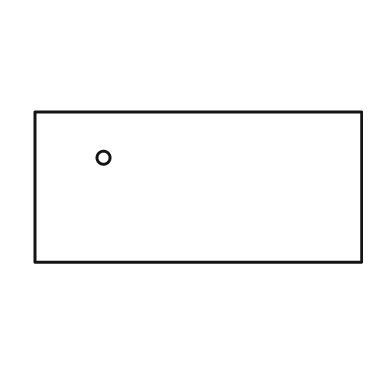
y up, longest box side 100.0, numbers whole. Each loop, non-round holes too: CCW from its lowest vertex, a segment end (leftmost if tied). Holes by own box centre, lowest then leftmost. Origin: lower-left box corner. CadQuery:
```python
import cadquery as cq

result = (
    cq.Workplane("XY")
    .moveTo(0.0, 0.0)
    .lineTo(100.0, 0.0)
    .lineTo(100.0, 46.0)
    .lineTo(0.0, 46.0)
    .close()
    .moveTo(21.0, 32.0)
    .circle(2.0)
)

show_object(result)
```